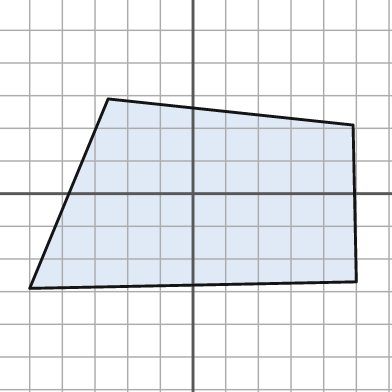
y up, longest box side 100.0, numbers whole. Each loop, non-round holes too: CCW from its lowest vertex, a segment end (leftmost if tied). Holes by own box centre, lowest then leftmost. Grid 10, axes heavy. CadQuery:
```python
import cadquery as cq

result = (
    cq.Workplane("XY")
    .moveTo(-50.0, -29.0)
    .lineTo(50.0, -27.0)
    .lineTo(49.0, 21.0)
    .lineTo(-26.0, 29.0)
    .close()
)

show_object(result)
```